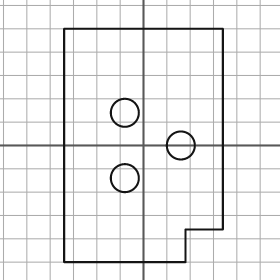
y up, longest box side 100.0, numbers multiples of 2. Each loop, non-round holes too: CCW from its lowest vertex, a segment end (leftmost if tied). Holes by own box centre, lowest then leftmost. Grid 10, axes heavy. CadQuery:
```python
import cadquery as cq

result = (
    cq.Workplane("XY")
    .moveTo(-34.0, -50.0)
    .lineTo(18.0, -50.0)
    .lineTo(18.0, -36.0)
    .lineTo(34.0, -36.0)
    .lineTo(34.0, 50.0)
    .lineTo(-34.0, 50.0)
    .close()
    .moveTo(-8.0, -14.0)
    .circle(6.0)
    .moveTo(16.0, 0.0)
    .circle(6.0)
    .moveTo(-8.0, 14.0)
    .circle(6.0)
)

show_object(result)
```